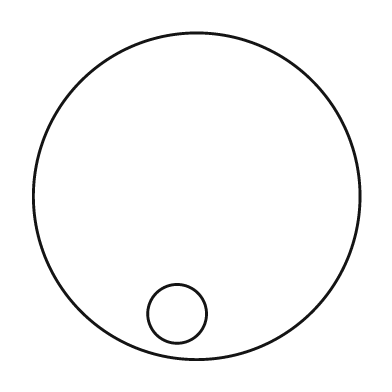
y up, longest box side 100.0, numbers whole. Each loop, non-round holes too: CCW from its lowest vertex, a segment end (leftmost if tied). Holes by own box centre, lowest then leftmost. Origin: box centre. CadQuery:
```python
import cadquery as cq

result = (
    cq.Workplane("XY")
    .moveTo(0.0, 0.0)
    .circle(50.0)
    .moveTo(-6.0, -36.0)
    .circle(9.0)
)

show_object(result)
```